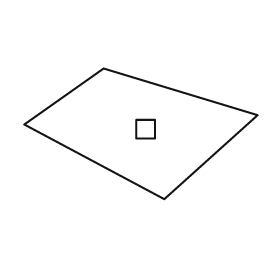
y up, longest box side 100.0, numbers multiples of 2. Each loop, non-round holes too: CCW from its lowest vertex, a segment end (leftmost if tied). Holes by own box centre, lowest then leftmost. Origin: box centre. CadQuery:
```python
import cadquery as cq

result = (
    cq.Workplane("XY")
    .moveTo(10.0, -28.0)
    .lineTo(50.0, 8.0)
    .lineTo(-16.0, 28.0)
    .lineTo(-50.0, 4.0)
    .close()
    .moveTo(-2.0, -2.0)
    .lineTo(6.0, -2.0)
    .lineTo(6.0, 6.0)
    .lineTo(-2.0, 6.0)
    .close()
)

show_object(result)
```